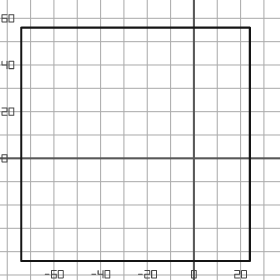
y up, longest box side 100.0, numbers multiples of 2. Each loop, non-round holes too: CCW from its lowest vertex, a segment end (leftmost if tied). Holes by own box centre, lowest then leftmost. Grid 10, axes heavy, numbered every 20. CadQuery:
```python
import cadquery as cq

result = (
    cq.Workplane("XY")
    .moveTo(-74.0, -44.0)
    .lineTo(24.0, -44.0)
    .lineTo(24.0, 56.0)
    .lineTo(-74.0, 56.0)
    .close()
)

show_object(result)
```